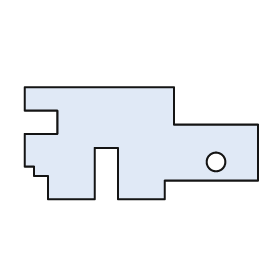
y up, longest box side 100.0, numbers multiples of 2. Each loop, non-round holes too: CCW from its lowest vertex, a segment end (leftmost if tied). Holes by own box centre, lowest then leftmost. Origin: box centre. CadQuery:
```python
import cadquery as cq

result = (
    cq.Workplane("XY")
    .moveTo(-40.0, -24.0)
    .lineTo(-20.0, -24.0)
    .lineTo(-20.0, -2.0)
    .lineTo(-10.0, -2.0)
    .lineTo(-10.0, -24.0)
    .lineTo(10.0, -24.0)
    .lineTo(10.0, -16.0)
    .lineTo(50.0, -16.0)
    .lineTo(50.0, 8.0)
    .lineTo(14.0, 8.0)
    .lineTo(14.0, 24.0)
    .lineTo(-50.0, 24.0)
    .lineTo(-50.0, 14.0)
    .lineTo(-36.0, 14.0)
    .lineTo(-36.0, 4.0)
    .lineTo(-50.0, 4.0)
    .lineTo(-50.0, -10.0)
    .lineTo(-46.0, -10.0)
    .lineTo(-46.0, -14.0)
    .lineTo(-40.0, -14.0)
    .close()
    .moveTo(32.0, -8.0)
    .circle(4.0)
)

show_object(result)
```